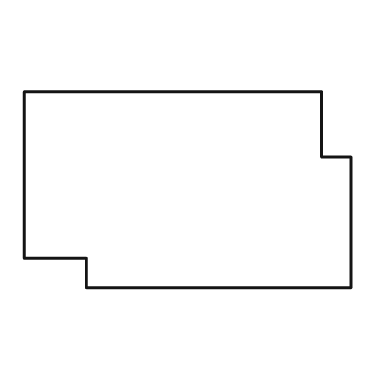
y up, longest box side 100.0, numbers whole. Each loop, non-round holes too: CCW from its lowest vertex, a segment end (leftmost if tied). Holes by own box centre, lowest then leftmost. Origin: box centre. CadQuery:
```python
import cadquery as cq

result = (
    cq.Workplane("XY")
    .moveTo(-31.0, -30.0)
    .lineTo(50.0, -30.0)
    .lineTo(50.0, 10.0)
    .lineTo(41.0, 10.0)
    .lineTo(41.0, 30.0)
    .lineTo(-50.0, 30.0)
    .lineTo(-50.0, -21.0)
    .lineTo(-31.0, -21.0)
    .close()
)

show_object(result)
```